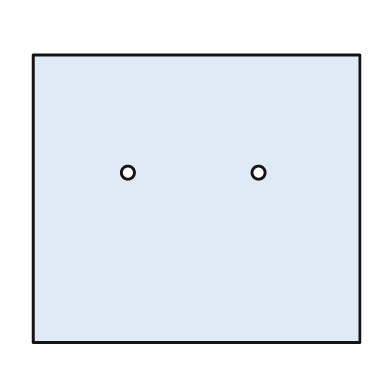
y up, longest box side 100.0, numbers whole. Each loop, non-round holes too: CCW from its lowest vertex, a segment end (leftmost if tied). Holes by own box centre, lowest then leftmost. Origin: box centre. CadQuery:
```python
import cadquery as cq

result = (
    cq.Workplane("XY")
    .moveTo(-50.0, -44.0)
    .lineTo(50.0, -44.0)
    .lineTo(50.0, 44.0)
    .lineTo(-50.0, 44.0)
    .close()
    .moveTo(-21.0, 8.0)
    .circle(2.0)
    .moveTo(19.0, 8.0)
    .circle(2.0)
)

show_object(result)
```